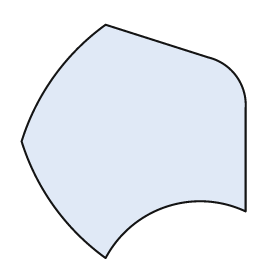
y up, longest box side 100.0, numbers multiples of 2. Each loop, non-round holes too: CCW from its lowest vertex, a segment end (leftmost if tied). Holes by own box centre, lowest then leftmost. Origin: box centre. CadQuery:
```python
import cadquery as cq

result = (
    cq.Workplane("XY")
    .moveTo(-12.0, -50.0)
    .threePointArc((14.0, -28.0), (48.0, -30.0))
    .lineTo(48.0, 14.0)
    .threePointArc((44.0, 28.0), (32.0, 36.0))
    .lineTo(-12.0, 50.0)
    .threePointArc((-34.0, 28.0), (-48.0, 0.0))
    .threePointArc((-34.0, -28.0), (-12.0, -50.0))
    .close()
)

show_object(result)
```